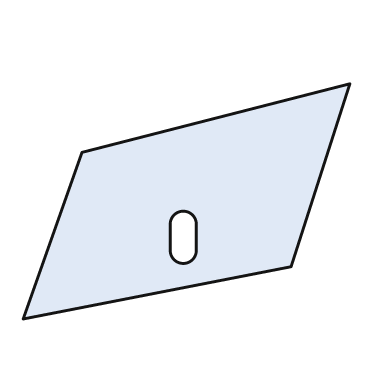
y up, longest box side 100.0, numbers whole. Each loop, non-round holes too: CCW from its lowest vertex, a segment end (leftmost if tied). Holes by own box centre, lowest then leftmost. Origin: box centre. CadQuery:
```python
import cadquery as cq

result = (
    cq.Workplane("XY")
    .moveTo(-50.0, -36.0)
    .lineTo(32.0, -20.0)
    .lineTo(50.0, 36.0)
    .lineTo(-32.0, 15.0)
    .close()
    .moveTo(-5.0, -15.0)
    .threePointArc((-1.0, -19.0), (3.0, -15.0))
    .lineTo(3.0, -7.0)
    .threePointArc((-1.0, -3.0), (-5.0, -7.0))
    .close()
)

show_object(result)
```